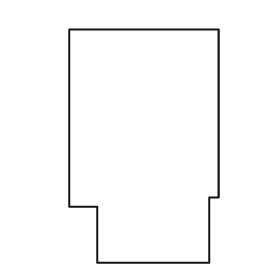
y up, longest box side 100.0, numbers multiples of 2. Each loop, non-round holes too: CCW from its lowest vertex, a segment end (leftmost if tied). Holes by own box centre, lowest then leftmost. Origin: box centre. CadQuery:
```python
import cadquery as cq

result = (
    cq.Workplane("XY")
    .moveTo(-20.0, -50.0)
    .lineTo(28.0, -50.0)
    .lineTo(28.0, -22.0)
    .lineTo(32.0, -22.0)
    .lineTo(32.0, 50.0)
    .lineTo(-32.0, 50.0)
    .lineTo(-32.0, -26.0)
    .lineTo(-20.0, -26.0)
    .close()
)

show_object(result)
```